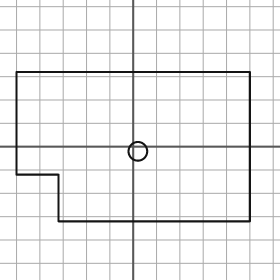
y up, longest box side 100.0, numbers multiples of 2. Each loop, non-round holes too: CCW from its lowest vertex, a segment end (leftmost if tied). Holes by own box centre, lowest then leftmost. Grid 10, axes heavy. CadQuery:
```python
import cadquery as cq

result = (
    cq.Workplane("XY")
    .moveTo(-32.0, -32.0)
    .lineTo(50.0, -32.0)
    .lineTo(50.0, 32.0)
    .lineTo(-50.0, 32.0)
    .lineTo(-50.0, -12.0)
    .lineTo(-32.0, -12.0)
    .close()
    .moveTo(2.0, -2.0)
    .circle(4.0)
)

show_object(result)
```